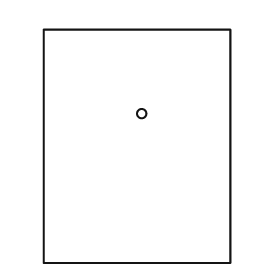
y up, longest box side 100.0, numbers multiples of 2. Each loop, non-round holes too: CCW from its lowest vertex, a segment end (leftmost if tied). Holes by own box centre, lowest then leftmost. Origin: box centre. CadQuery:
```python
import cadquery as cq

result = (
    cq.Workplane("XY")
    .moveTo(-40.0, -50.0)
    .lineTo(40.0, -50.0)
    .lineTo(40.0, 50.0)
    .lineTo(-40.0, 50.0)
    .close()
    .moveTo(2.0, 14.0)
    .circle(2.0)
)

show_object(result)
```